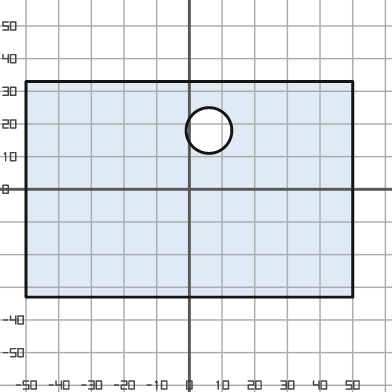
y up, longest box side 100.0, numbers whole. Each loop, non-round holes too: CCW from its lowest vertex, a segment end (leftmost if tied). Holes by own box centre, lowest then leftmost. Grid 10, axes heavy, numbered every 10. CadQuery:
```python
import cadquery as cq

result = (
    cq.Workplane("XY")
    .moveTo(-50.0, -33.0)
    .lineTo(50.0, -33.0)
    .lineTo(50.0, 33.0)
    .lineTo(-50.0, 33.0)
    .close()
    .moveTo(6.0, 18.0)
    .circle(7.0)
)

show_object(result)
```